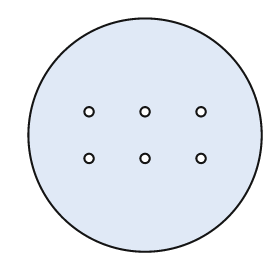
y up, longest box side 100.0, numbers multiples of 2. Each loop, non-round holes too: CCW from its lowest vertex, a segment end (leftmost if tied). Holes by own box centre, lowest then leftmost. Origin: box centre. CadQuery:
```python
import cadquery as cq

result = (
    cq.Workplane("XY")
    .moveTo(0.0, 0.0)
    .circle(50.0)
    .moveTo(-24.0, -10.0)
    .circle(2.0)
    .moveTo(0.0, -10.0)
    .circle(2.0)
    .moveTo(24.0, -10.0)
    .circle(2.0)
    .moveTo(-24.0, 10.0)
    .circle(2.0)
    .moveTo(0.0, 10.0)
    .circle(2.0)
    .moveTo(24.0, 10.0)
    .circle(2.0)
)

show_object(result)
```